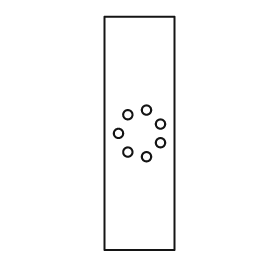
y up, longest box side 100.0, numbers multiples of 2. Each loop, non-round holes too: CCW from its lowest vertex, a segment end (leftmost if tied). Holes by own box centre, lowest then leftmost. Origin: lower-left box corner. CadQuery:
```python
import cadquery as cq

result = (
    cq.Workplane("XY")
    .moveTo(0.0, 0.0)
    .lineTo(30.0, 0.0)
    .lineTo(30.0, 100.0)
    .lineTo(0.0, 100.0)
    .close()
    .moveTo(18.0, 40.0)
    .circle(2.0)
    .moveTo(10.0, 42.0)
    .circle(2.0)
    .moveTo(24.0, 46.0)
    .circle(2.0)
    .moveTo(6.0, 50.0)
    .circle(2.0)
    .moveTo(24.0, 54.0)
    .circle(2.0)
    .moveTo(10.0, 58.0)
    .circle(2.0)
    .moveTo(18.0, 60.0)
    .circle(2.0)
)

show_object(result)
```